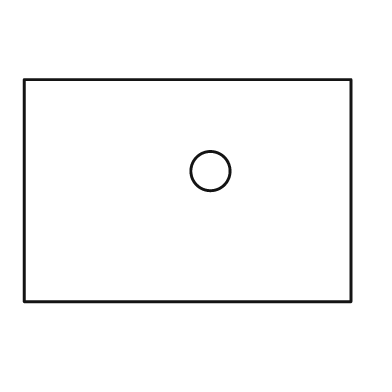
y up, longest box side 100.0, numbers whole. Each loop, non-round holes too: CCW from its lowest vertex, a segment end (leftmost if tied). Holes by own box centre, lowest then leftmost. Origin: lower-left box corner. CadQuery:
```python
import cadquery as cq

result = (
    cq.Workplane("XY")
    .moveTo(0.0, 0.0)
    .lineTo(100.0, 0.0)
    .lineTo(100.0, 68.0)
    .lineTo(0.0, 68.0)
    .close()
    .moveTo(57.0, 40.0)
    .circle(6.0)
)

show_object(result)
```